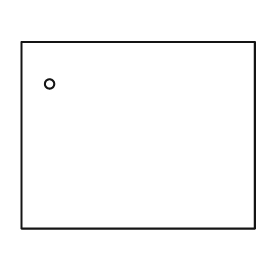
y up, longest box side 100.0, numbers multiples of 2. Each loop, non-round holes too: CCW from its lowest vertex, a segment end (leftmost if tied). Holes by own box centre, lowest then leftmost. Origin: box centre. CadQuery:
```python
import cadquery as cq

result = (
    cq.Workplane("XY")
    .moveTo(-50.0, -40.0)
    .lineTo(50.0, -40.0)
    .lineTo(50.0, 40.0)
    .lineTo(-50.0, 40.0)
    .close()
    .moveTo(-38.0, 22.0)
    .circle(2.0)
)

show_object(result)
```